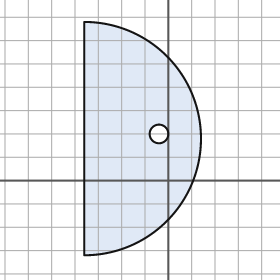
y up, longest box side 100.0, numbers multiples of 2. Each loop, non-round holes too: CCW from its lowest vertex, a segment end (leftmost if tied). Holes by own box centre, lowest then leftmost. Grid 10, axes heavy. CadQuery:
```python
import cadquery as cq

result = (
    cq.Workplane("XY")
    .moveTo(-36.0, -32.0)
    .threePointArc((14.0, 18.0), (-36.0, 68.0))
    .close()
    .moveTo(-4.0, 20.0)
    .circle(4.0)
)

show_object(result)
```